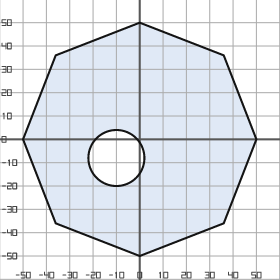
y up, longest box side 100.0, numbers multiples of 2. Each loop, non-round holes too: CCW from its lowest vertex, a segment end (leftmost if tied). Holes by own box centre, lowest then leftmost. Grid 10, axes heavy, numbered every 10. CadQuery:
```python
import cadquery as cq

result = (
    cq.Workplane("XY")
    .moveTo(0.0, -50.0)
    .lineTo(36.0, -36.0)
    .lineTo(50.0, 0.0)
    .lineTo(36.0, 36.0)
    .lineTo(0.0, 50.0)
    .lineTo(-36.0, 36.0)
    .lineTo(-50.0, 0.0)
    .lineTo(-36.0, -36.0)
    .close()
    .moveTo(-10.0, -8.0)
    .circle(12.0)
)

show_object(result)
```